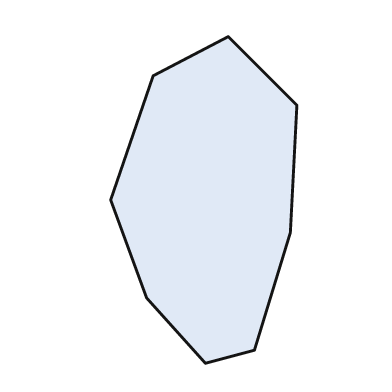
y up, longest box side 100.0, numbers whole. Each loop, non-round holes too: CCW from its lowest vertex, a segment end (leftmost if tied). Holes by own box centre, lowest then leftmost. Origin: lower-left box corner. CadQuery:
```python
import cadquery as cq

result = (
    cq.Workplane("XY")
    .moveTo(29.0, 0.0)
    .lineTo(44.0, 4.0)
    .lineTo(55.0, 40.0)
    .lineTo(57.0, 79.0)
    .lineTo(36.0, 100.0)
    .lineTo(13.0, 88.0)
    .lineTo(0.0, 50.0)
    .lineTo(11.0, 20.0)
    .close()
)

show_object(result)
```